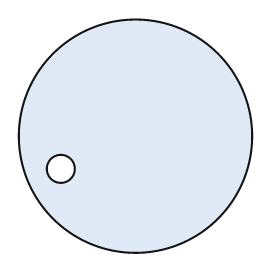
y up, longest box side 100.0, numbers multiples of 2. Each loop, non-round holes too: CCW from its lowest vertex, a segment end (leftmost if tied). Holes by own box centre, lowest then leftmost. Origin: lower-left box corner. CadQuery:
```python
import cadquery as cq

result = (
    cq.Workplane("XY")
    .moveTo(50.0, 50.0)
    .circle(50.0)
    .moveTo(18.0, 36.0)
    .circle(6.0)
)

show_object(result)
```